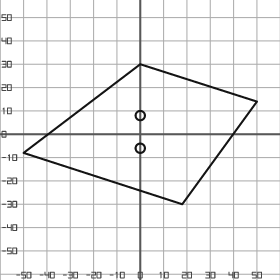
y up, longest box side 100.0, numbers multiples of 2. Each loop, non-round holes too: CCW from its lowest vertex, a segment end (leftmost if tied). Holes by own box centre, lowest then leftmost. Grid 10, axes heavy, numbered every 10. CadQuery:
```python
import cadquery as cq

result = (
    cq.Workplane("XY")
    .moveTo(18.0, -30.0)
    .lineTo(50.0, 14.0)
    .lineTo(0.0, 30.0)
    .lineTo(-50.0, -8.0)
    .close()
    .moveTo(0.0, -6.0)
    .circle(2.0)
    .moveTo(0.0, 8.0)
    .circle(2.0)
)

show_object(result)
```